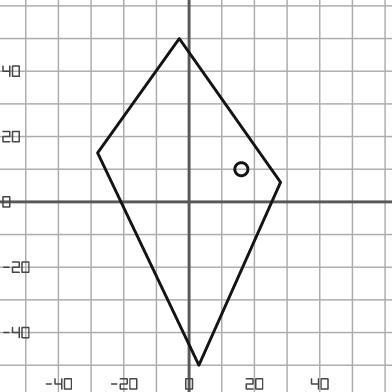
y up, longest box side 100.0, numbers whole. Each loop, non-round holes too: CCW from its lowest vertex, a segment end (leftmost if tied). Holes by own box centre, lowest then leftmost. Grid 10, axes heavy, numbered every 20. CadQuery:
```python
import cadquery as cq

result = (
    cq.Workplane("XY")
    .moveTo(3.0, -50.0)
    .lineTo(28.0, 6.0)
    .lineTo(-3.0, 50.0)
    .lineTo(-28.0, 15.0)
    .close()
    .moveTo(16.0, 10.0)
    .circle(2.0)
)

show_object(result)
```